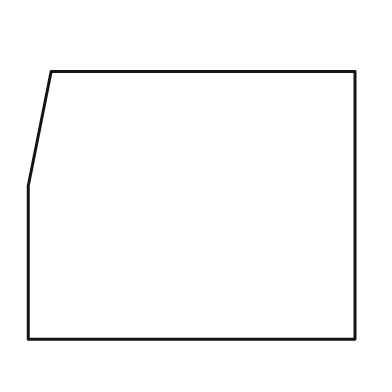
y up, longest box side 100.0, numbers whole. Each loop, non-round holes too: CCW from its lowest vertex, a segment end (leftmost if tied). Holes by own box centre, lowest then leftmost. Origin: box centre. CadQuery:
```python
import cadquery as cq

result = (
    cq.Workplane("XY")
    .moveTo(-50.0, -41.0)
    .lineTo(50.0, -41.0)
    .lineTo(50.0, 41.0)
    .lineTo(-43.0, 41.0)
    .lineTo(-50.0, 6.0)
    .close()
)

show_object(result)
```